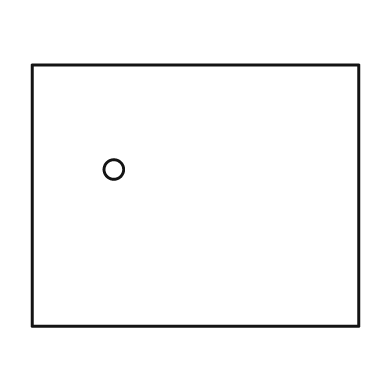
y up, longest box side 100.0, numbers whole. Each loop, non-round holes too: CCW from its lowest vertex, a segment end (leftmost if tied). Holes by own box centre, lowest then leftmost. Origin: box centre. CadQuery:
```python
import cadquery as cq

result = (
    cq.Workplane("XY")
    .moveTo(-50.0, -40.0)
    .lineTo(50.0, -40.0)
    .lineTo(50.0, 40.0)
    .lineTo(-50.0, 40.0)
    .close()
    .moveTo(-25.0, 8.0)
    .circle(3.0)
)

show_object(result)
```